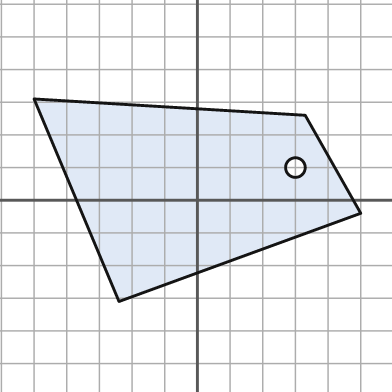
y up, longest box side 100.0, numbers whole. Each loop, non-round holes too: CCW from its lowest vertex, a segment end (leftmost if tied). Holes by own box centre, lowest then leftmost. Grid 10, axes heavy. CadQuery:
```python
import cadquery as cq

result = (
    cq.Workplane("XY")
    .moveTo(-24.0, -31.0)
    .lineTo(50.0, -4.0)
    .lineTo(33.0, 26.0)
    .lineTo(-50.0, 31.0)
    .close()
    .moveTo(30.0, 10.0)
    .circle(3.0)
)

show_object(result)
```